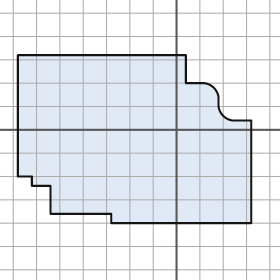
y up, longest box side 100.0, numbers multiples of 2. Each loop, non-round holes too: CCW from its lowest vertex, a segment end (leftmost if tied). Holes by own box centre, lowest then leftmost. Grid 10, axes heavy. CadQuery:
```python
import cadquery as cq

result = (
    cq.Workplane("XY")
    .moveTo(-28.0, -40.0)
    .lineTo(32.0, -40.0)
    .lineTo(32.0, 4.0)
    .lineTo(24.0, 4.0)
    .threePointArc((20.0, 6.0), (18.0, 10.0))
    .lineTo(18.0, 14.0)
    .threePointArc((16.0, 18.0), (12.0, 20.0))
    .lineTo(4.0, 20.0)
    .lineTo(4.0, 32.0)
    .lineTo(-68.0, 32.0)
    .lineTo(-68.0, -20.0)
    .lineTo(-62.0, -20.0)
    .lineTo(-62.0, -24.0)
    .lineTo(-54.0, -24.0)
    .lineTo(-54.0, -36.0)
    .lineTo(-28.0, -36.0)
    .close()
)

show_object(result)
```